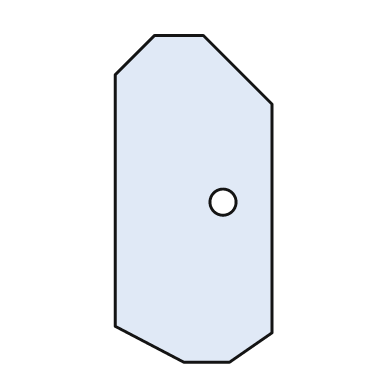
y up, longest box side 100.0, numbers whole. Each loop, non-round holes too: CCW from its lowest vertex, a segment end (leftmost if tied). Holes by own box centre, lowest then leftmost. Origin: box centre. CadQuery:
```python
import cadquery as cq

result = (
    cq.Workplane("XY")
    .moveTo(-3.0, -50.0)
    .lineTo(11.0, -50.0)
    .lineTo(24.0, -41.0)
    .lineTo(24.0, 29.0)
    .lineTo(3.0, 50.0)
    .lineTo(-12.0, 50.0)
    .lineTo(-24.0, 38.0)
    .lineTo(-24.0, -39.0)
    .close()
    .moveTo(9.0, -1.0)
    .circle(4.0)
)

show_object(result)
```